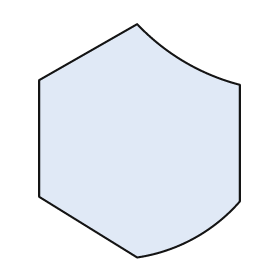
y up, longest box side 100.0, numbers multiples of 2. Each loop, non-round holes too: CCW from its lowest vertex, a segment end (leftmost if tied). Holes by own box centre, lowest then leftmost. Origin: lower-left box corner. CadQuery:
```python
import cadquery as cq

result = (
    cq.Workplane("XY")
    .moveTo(42.0, 0.0)
    .threePointArc((66.0, 8.0), (86.0, 24.0))
    .lineTo(86.0, 74.0)
    .threePointArc((62.0, 84.0), (42.0, 100.0))
    .lineTo(0.0, 76.0)
    .lineTo(0.0, 26.0)
    .close()
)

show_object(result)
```